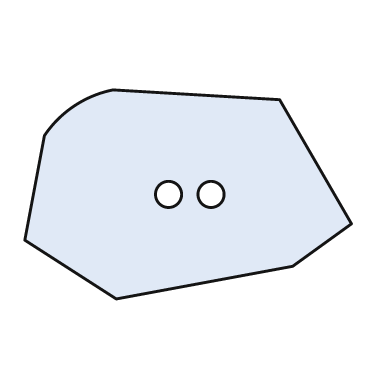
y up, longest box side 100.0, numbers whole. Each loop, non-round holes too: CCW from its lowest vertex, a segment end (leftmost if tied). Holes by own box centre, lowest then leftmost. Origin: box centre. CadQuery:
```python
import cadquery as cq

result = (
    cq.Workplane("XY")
    .moveTo(-22.0, -32.0)
    .lineTo(32.0, -22.0)
    .lineTo(50.0, -9.0)
    .lineTo(28.0, 29.0)
    .lineTo(-23.0, 32.0)
    .threePointArc((-35.0, 27.0), (-44.0, 18.0))
    .lineTo(-50.0, -14.0)
    .close()
    .moveTo(-6.0, 0.0)
    .circle(4.0)
    .moveTo(7.0, 0.0)
    .circle(4.0)
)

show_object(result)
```